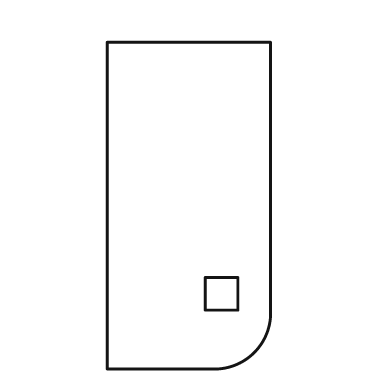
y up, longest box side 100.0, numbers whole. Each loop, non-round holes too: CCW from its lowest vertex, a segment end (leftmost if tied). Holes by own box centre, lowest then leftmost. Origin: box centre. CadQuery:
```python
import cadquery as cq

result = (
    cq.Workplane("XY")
    .moveTo(-25.0, -50.0)
    .lineTo(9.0, -50.0)
    .threePointArc((20.0, -45.0), (25.0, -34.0))
    .lineTo(25.0, 50.0)
    .lineTo(-25.0, 50.0)
    .close()
    .moveTo(5.0, -32.0)
    .lineTo(15.0, -32.0)
    .lineTo(15.0, -22.0)
    .lineTo(5.0, -22.0)
    .close()
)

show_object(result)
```